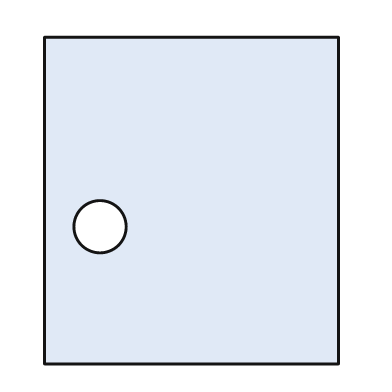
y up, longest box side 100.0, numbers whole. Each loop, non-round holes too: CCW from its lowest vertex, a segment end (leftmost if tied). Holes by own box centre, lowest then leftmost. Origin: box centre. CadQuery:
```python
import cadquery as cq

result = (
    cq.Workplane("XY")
    .moveTo(-45.0, -50.0)
    .lineTo(45.0, -50.0)
    .lineTo(45.0, 50.0)
    .lineTo(-45.0, 50.0)
    .close()
    .moveTo(-28.0, -8.0)
    .circle(8.0)
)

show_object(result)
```